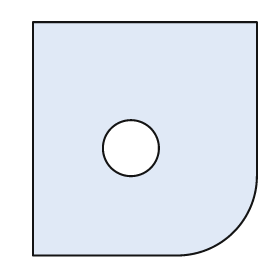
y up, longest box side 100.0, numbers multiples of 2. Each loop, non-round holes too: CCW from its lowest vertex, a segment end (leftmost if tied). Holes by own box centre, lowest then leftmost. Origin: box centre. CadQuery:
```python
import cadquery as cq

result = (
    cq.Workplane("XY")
    .moveTo(-48.0, -50.0)
    .lineTo(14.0, -50.0)
    .threePointArc((38.0, -40.0), (48.0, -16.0))
    .lineTo(48.0, 50.0)
    .lineTo(-48.0, 50.0)
    .close()
    .moveTo(-6.0, -4.0)
    .circle(12.0)
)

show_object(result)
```